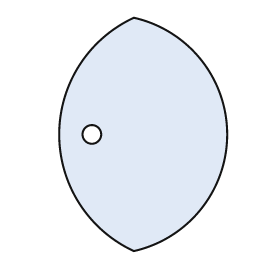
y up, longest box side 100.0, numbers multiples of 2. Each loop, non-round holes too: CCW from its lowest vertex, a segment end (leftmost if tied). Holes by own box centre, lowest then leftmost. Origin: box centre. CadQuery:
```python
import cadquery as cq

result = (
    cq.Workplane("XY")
    .moveTo(-4.0, -50.0)
    .threePointArc((36.0, 0.0), (-4.0, 50.0))
    .threePointArc((-36.0, 0.0), (-4.0, -50.0))
    .close()
    .moveTo(-22.0, 0.0)
    .circle(4.0)
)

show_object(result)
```